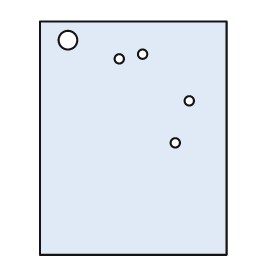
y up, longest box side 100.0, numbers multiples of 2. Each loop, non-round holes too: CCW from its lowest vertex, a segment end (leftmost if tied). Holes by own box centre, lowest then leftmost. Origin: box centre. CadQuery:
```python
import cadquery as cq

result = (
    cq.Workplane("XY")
    .moveTo(-40.0, -50.0)
    .lineTo(40.0, -50.0)
    .lineTo(40.0, 50.0)
    .lineTo(-40.0, 50.0)
    .close()
    .moveTo(18.0, -2.0)
    .circle(2.0)
    .moveTo(24.0, 16.0)
    .circle(2.0)
    .moveTo(-6.0, 34.0)
    .circle(2.0)
    .moveTo(4.0, 36.0)
    .circle(2.0)
    .moveTo(-28.0, 42.0)
    .circle(4.0)
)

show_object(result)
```